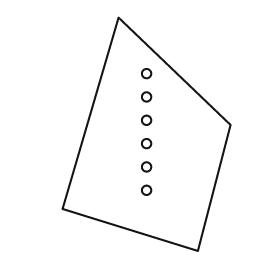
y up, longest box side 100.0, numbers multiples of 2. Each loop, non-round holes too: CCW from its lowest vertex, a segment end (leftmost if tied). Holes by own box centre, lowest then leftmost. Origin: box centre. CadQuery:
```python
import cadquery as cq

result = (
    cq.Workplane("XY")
    .moveTo(22.0, -50.0)
    .lineTo(36.0, 4.0)
    .lineTo(-12.0, 50.0)
    .lineTo(-36.0, -32.0)
    .close()
    .moveTo(0.0, -24.0)
    .circle(2.0)
    .moveTo(0.0, -14.0)
    .circle(2.0)
    .moveTo(0.0, -4.0)
    .circle(2.0)
    .moveTo(0.0, 6.0)
    .circle(2.0)
    .moveTo(0.0, 16.0)
    .circle(2.0)
    .moveTo(0.0, 26.0)
    .circle(2.0)
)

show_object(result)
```